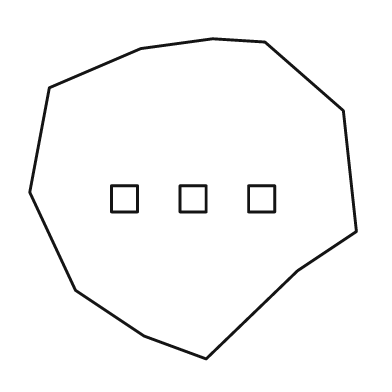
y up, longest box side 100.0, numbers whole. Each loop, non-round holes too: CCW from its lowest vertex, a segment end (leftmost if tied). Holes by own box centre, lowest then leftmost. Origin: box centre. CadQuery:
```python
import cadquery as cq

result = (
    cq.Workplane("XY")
    .moveTo(4.0, -49.0)
    .lineTo(32.0, -22.0)
    .lineTo(50.0, -10.0)
    .lineTo(46.0, 27.0)
    .lineTo(22.0, 48.0)
    .lineTo(6.0, 49.0)
    .lineTo(-16.0, 46.0)
    .lineTo(-44.0, 34.0)
    .lineTo(-50.0, 2.0)
    .lineTo(-36.0, -28.0)
    .lineTo(-15.0, -42.0)
    .close()
    .moveTo(-25.0, -4.0)
    .lineTo(-17.0, -4.0)
    .lineTo(-17.0, 4.0)
    .lineTo(-25.0, 4.0)
    .close()
    .moveTo(-4.0, -4.0)
    .lineTo(4.0, -4.0)
    .lineTo(4.0, 4.0)
    .lineTo(-4.0, 4.0)
    .close()
    .moveTo(17.0, -4.0)
    .lineTo(25.0, -4.0)
    .lineTo(25.0, 4.0)
    .lineTo(17.0, 4.0)
    .close()
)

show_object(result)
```